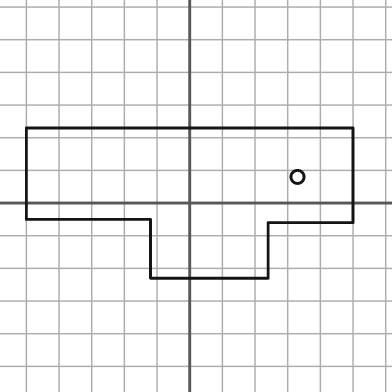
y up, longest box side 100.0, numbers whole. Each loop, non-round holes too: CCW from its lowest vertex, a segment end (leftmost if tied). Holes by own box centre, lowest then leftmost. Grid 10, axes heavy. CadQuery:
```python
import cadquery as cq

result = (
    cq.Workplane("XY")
    .moveTo(-12.0, -23.0)
    .lineTo(24.0, -23.0)
    .lineTo(24.0, -6.0)
    .lineTo(50.0, -6.0)
    .lineTo(50.0, 23.0)
    .lineTo(-50.0, 23.0)
    .lineTo(-50.0, -5.0)
    .lineTo(-12.0, -5.0)
    .close()
    .moveTo(33.0, 8.0)
    .circle(2.0)
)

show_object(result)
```